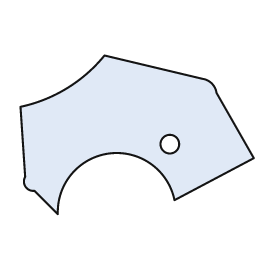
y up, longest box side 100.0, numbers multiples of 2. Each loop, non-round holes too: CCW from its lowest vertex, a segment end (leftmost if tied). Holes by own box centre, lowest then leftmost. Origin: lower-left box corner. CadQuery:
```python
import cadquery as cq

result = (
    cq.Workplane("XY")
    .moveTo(16.0, 0.0)
    .threePointArc((38.0, 26.0), (66.0, 6.0))
    .lineTo(100.0, 24.0)
    .lineTo(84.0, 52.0)
    .threePointArc((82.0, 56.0), (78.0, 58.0))
    .lineTo(36.0, 68.0)
    .threePointArc((20.0, 54.0), (0.0, 46.0))
    .lineTo(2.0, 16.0)
    .threePointArc((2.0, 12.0), (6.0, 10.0))
    .close()
    .moveTo(64.0, 30.0)
    .circle(4.0)
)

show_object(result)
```